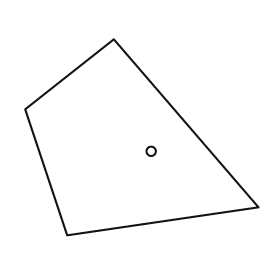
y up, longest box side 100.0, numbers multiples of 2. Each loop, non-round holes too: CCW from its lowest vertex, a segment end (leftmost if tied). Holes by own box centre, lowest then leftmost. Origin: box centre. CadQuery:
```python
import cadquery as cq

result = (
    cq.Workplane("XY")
    .moveTo(-32.0, -42.0)
    .lineTo(50.0, -30.0)
    .lineTo(-12.0, 42.0)
    .lineTo(-50.0, 12.0)
    .close()
    .moveTo(4.0, -6.0)
    .circle(2.0)
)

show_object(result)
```